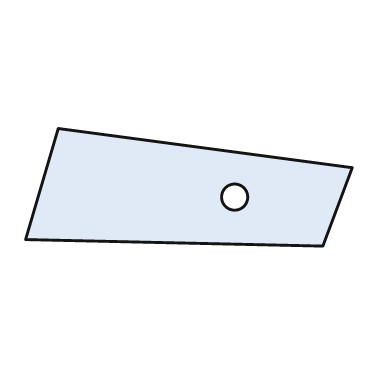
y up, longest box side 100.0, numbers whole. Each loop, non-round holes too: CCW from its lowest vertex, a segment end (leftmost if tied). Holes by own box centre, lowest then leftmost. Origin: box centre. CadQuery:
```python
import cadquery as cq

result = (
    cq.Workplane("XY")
    .moveTo(41.0, -18.0)
    .lineTo(50.0, 6.0)
    .lineTo(-40.0, 18.0)
    .lineTo(-50.0, -16.0)
    .close()
    .moveTo(14.0, -3.0)
    .circle(4.0)
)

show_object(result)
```